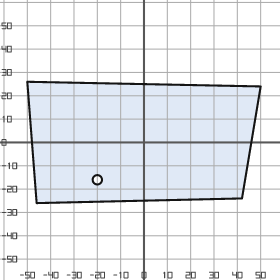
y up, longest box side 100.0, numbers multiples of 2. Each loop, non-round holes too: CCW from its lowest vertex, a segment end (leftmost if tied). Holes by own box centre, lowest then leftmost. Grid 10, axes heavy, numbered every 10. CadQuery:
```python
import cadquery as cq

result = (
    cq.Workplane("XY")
    .moveTo(-46.0, -26.0)
    .lineTo(42.0, -24.0)
    .lineTo(50.0, 24.0)
    .lineTo(-50.0, 26.0)
    .close()
    .moveTo(-20.0, -16.0)
    .circle(2.0)
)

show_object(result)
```